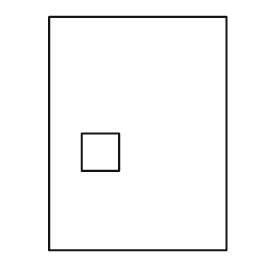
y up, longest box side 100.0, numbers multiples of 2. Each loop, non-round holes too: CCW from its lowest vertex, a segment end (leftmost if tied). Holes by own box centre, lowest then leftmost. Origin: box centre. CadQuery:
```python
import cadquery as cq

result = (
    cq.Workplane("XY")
    .moveTo(-38.0, -50.0)
    .lineTo(38.0, -50.0)
    .lineTo(38.0, 50.0)
    .lineTo(-38.0, 50.0)
    .close()
    .moveTo(-24.0, -16.0)
    .lineTo(-8.0, -16.0)
    .lineTo(-8.0, 0.0)
    .lineTo(-24.0, 0.0)
    .close()
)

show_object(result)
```